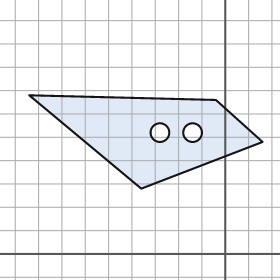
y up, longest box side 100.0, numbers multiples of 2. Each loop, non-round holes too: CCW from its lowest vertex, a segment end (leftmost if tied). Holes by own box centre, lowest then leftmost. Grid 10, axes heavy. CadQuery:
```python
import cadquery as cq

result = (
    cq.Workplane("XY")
    .moveTo(-36.0, 28.0)
    .lineTo(16.0, 48.0)
    .lineTo(-4.0, 66.0)
    .lineTo(-84.0, 68.0)
    .close()
    .moveTo(-28.0, 52.0)
    .circle(4.0)
    .moveTo(-14.0, 52.0)
    .circle(4.0)
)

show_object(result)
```